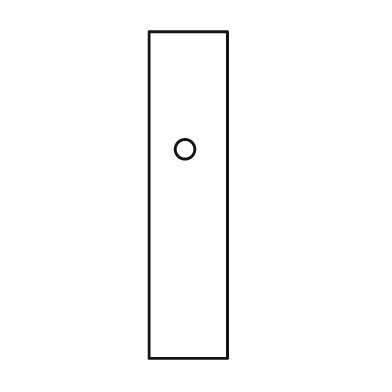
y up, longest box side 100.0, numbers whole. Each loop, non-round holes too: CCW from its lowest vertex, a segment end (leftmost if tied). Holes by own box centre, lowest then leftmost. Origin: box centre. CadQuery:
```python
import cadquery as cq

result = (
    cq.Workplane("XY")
    .moveTo(-12.0, -50.0)
    .lineTo(12.0, -50.0)
    .lineTo(12.0, 50.0)
    .lineTo(-12.0, 50.0)
    .close()
    .moveTo(-1.0, 14.0)
    .circle(3.0)
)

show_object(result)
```